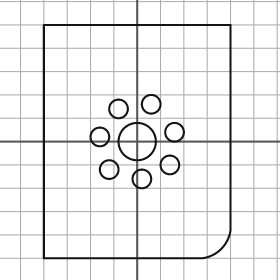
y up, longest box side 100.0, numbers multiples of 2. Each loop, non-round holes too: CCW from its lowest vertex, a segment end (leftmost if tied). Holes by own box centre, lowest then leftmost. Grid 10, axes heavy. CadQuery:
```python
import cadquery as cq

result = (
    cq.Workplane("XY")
    .moveTo(-40.0, -50.0)
    .lineTo(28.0, -50.0)
    .threePointArc((36.0, -46.0), (40.0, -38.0))
    .lineTo(40.0, 50.0)
    .lineTo(-40.0, 50.0)
    .close()
    .moveTo(2.0, -16.0)
    .circle(4.0)
    .moveTo(-12.0, -12.0)
    .circle(4.0)
    .moveTo(14.0, -10.0)
    .circle(4.0)
    .moveTo(0.0, 0.0)
    .circle(8.0)
    .moveTo(-16.0, 2.0)
    .circle(4.0)
    .moveTo(16.0, 4.0)
    .circle(4.0)
    .moveTo(-8.0, 14.0)
    .circle(4.0)
    .moveTo(6.0, 16.0)
    .circle(4.0)
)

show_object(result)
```